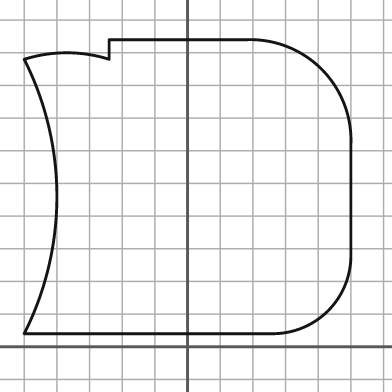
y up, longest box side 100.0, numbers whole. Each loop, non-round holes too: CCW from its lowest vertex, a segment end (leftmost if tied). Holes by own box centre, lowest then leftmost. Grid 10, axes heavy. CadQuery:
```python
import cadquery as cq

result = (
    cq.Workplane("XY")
    .moveTo(-50.0, 4.0)
    .lineTo(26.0, 4.0)
    .threePointArc((43.0, 11.0), (50.0, 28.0))
    .lineTo(50.0, 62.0)
    .threePointArc((41.0, 85.0), (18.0, 94.0))
    .lineTo(-24.0, 94.0)
    .lineTo(-24.0, 88.0)
    .threePointArc((-37.0, 90.0), (-50.0, 88.0))
    .threePointArc((-40.0, 46.0), (-50.0, 4.0))
    .close()
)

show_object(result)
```